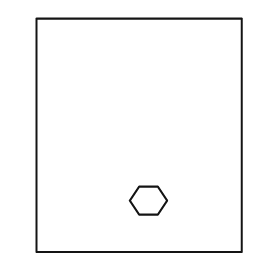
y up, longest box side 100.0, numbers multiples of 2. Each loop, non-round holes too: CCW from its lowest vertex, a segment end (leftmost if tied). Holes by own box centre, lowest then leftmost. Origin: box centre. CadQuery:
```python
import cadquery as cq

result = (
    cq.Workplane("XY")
    .moveTo(-44.0, -50.0)
    .lineTo(44.0, -50.0)
    .lineTo(44.0, 50.0)
    .lineTo(-44.0, 50.0)
    .close()
    .moveTo(0.0, -34.0)
    .lineTo(8.0, -34.0)
    .lineTo(12.0, -28.0)
    .lineTo(8.0, -22.0)
    .lineTo(0.0, -22.0)
    .lineTo(-4.0, -28.0)
    .close()
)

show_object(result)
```